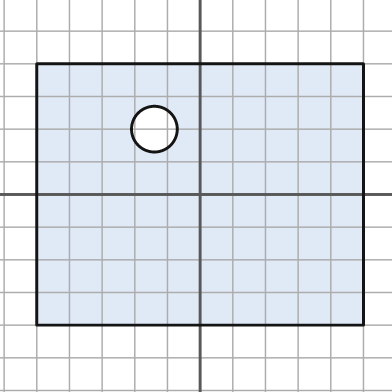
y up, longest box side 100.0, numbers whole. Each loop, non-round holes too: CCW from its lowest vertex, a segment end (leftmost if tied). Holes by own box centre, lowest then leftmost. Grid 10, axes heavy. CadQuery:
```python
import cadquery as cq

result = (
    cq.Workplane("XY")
    .moveTo(-50.0, -40.0)
    .lineTo(50.0, -40.0)
    .lineTo(50.0, 40.0)
    .lineTo(-50.0, 40.0)
    .close()
    .moveTo(-14.0, 20.0)
    .circle(7.0)
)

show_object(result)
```